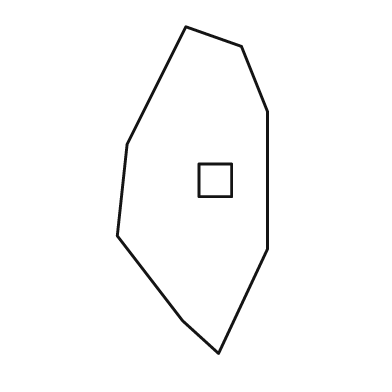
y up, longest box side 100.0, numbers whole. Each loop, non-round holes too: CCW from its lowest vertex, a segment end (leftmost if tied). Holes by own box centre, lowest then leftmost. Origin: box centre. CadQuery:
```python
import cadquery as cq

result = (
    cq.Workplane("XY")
    .moveTo(8.0, -50.0)
    .lineTo(23.0, -18.0)
    .lineTo(23.0, 24.0)
    .lineTo(15.0, 44.0)
    .lineTo(-2.0, 50.0)
    .lineTo(-20.0, 14.0)
    .lineTo(-23.0, -14.0)
    .lineTo(-3.0, -40.0)
    .close()
    .moveTo(2.0, -2.0)
    .lineTo(12.0, -2.0)
    .lineTo(12.0, 8.0)
    .lineTo(2.0, 8.0)
    .close()
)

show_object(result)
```